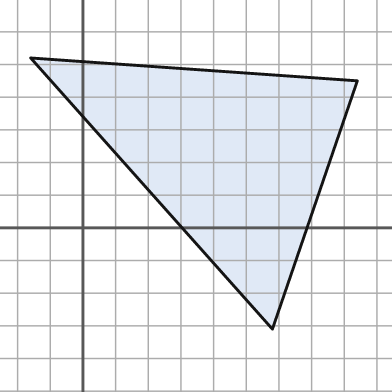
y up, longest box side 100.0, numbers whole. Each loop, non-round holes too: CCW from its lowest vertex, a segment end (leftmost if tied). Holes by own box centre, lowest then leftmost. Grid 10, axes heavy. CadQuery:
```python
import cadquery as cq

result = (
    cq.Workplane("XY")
    .moveTo(58.0, -31.0)
    .lineTo(84.0, 45.0)
    .lineTo(-16.0, 52.0)
    .close()
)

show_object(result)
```